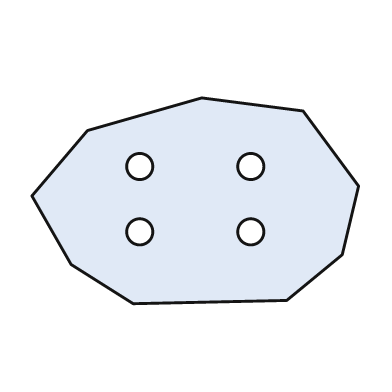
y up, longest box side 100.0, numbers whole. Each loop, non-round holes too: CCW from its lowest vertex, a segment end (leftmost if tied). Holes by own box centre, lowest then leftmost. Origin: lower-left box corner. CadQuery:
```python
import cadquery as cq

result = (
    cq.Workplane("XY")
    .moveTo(31.0, 0.0)
    .lineTo(78.0, 1.0)
    .lineTo(95.0, 15.0)
    .lineTo(100.0, 36.0)
    .lineTo(83.0, 59.0)
    .lineTo(52.0, 63.0)
    .lineTo(17.0, 53.0)
    .lineTo(0.0, 33.0)
    .lineTo(12.0, 12.0)
    .close()
    .moveTo(33.0, 22.0)
    .circle(4.0)
    .moveTo(67.0, 22.0)
    .circle(4.0)
    .moveTo(33.0, 42.0)
    .circle(4.0)
    .moveTo(67.0, 42.0)
    .circle(4.0)
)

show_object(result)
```